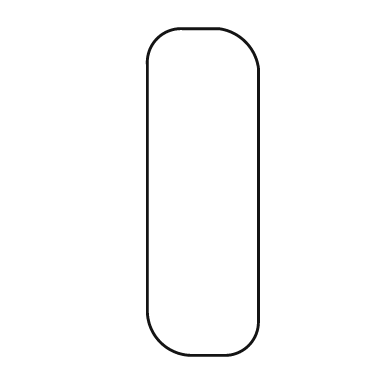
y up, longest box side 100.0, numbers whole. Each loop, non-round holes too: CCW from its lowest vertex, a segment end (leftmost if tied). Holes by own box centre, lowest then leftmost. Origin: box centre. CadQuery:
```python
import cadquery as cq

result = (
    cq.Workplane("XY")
    .moveTo(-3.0, -50.0)
    .lineTo(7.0, -50.0)
    .threePointArc((14.0, -47.0), (17.0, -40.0))
    .lineTo(17.0, 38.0)
    .threePointArc((13.0, 46.0), (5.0, 50.0))
    .lineTo(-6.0, 50.0)
    .threePointArc((-14.0, 47.0), (-17.0, 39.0))
    .lineTo(-17.0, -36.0)
    .threePointArc((-13.0, -46.0), (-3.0, -50.0))
    .close()
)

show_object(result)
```